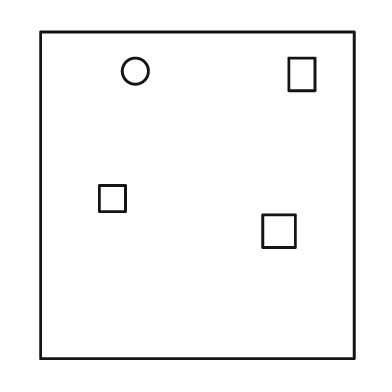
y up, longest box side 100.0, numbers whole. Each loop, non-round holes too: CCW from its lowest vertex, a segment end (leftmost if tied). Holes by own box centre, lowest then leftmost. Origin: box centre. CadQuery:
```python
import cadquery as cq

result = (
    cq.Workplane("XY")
    .moveTo(-48.0, -50.0)
    .lineTo(48.0, -50.0)
    .lineTo(48.0, 50.0)
    .lineTo(-48.0, 50.0)
    .close()
    .moveTo(20.0, -16.0)
    .lineTo(30.0, -16.0)
    .lineTo(30.0, -6.0)
    .lineTo(20.0, -6.0)
    .close()
    .moveTo(-30.0, -5.0)
    .lineTo(-22.0, -5.0)
    .lineTo(-22.0, 3.0)
    .lineTo(-30.0, 3.0)
    .close()
    .moveTo(28.0, 32.0)
    .lineTo(36.0, 32.0)
    .lineTo(36.0, 42.0)
    .lineTo(28.0, 42.0)
    .close()
    .moveTo(-19.0, 38.0)
    .circle(4.0)
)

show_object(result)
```